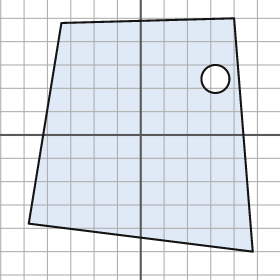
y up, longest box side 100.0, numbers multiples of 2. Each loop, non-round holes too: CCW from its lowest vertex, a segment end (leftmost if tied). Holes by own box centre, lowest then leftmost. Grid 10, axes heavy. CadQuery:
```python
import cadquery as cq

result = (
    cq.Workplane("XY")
    .moveTo(48.0, -50.0)
    .lineTo(40.0, 50.0)
    .lineTo(-34.0, 48.0)
    .lineTo(-48.0, -38.0)
    .close()
    .moveTo(32.0, 24.0)
    .circle(6.0)
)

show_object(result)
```